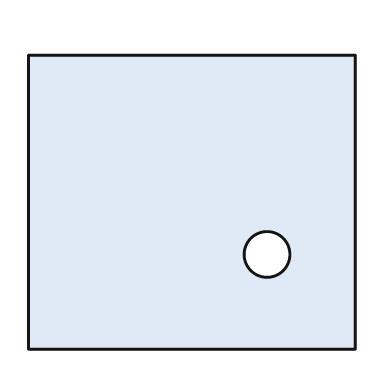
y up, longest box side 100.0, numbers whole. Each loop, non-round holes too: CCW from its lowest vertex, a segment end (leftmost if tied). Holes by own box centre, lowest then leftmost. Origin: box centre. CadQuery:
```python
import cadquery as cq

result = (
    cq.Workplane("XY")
    .moveTo(-50.0, -45.0)
    .lineTo(50.0, -45.0)
    .lineTo(50.0, 45.0)
    .lineTo(-50.0, 45.0)
    .close()
    .moveTo(23.0, -16.0)
    .circle(7.0)
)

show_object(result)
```